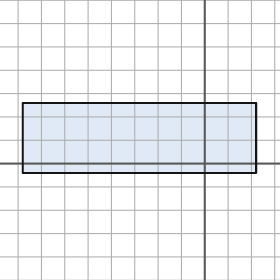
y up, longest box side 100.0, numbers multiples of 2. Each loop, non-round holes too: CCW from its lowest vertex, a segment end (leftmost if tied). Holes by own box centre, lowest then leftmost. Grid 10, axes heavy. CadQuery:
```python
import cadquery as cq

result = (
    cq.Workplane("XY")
    .moveTo(-78.0, -4.0)
    .lineTo(22.0, -4.0)
    .lineTo(22.0, 26.0)
    .lineTo(-78.0, 26.0)
    .close()
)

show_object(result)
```